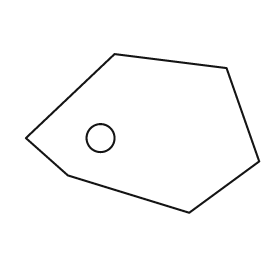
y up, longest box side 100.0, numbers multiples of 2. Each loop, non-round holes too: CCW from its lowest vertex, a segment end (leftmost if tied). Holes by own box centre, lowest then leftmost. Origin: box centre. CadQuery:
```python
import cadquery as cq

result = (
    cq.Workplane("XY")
    .moveTo(20.0, -34.0)
    .lineTo(50.0, -12.0)
    .lineTo(36.0, 28.0)
    .lineTo(-12.0, 34.0)
    .lineTo(-50.0, -2.0)
    .lineTo(-32.0, -18.0)
    .close()
    .moveTo(-18.0, -2.0)
    .circle(6.0)
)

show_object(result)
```